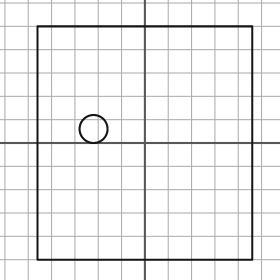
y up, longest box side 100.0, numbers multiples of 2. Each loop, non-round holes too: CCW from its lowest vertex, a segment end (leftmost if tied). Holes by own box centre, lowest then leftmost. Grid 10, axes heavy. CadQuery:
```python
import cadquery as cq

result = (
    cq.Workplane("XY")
    .moveTo(-46.0, -50.0)
    .lineTo(46.0, -50.0)
    .lineTo(46.0, 50.0)
    .lineTo(-46.0, 50.0)
    .close()
    .moveTo(-22.0, 6.0)
    .circle(6.0)
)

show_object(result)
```